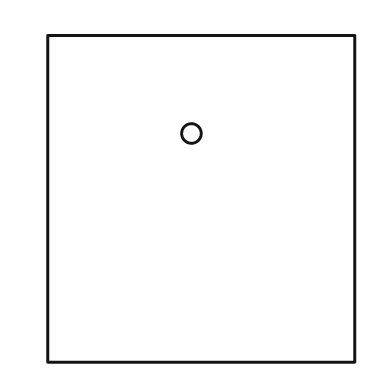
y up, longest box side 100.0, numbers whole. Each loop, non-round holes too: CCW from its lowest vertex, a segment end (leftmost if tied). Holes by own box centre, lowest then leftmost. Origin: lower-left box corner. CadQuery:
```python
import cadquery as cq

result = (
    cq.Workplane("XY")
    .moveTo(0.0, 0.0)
    .lineTo(94.0, 0.0)
    .lineTo(94.0, 100.0)
    .lineTo(0.0, 100.0)
    .close()
    .moveTo(44.0, 70.0)
    .circle(3.0)
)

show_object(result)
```